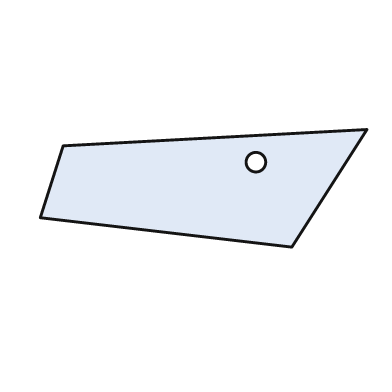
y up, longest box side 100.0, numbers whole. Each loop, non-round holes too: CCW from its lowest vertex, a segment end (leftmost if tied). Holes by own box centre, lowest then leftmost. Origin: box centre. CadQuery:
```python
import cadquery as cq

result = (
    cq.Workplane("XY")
    .moveTo(27.0, -18.0)
    .lineTo(50.0, 18.0)
    .lineTo(-43.0, 13.0)
    .lineTo(-50.0, -9.0)
    .close()
    .moveTo(16.0, 8.0)
    .circle(3.0)
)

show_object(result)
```